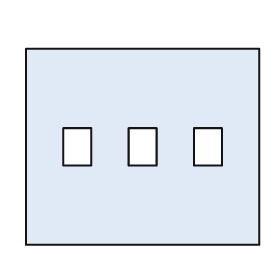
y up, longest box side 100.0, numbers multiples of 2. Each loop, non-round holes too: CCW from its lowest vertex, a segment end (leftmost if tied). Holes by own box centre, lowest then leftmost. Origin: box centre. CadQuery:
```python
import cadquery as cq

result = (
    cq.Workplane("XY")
    .moveTo(-50.0, -42.0)
    .lineTo(50.0, -42.0)
    .lineTo(50.0, 42.0)
    .lineTo(-50.0, 42.0)
    .close()
    .moveTo(-34.0, -8.0)
    .lineTo(-22.0, -8.0)
    .lineTo(-22.0, 8.0)
    .lineTo(-34.0, 8.0)
    .close()
    .moveTo(-6.0, -8.0)
    .lineTo(6.0, -8.0)
    .lineTo(6.0, 8.0)
    .lineTo(-6.0, 8.0)
    .close()
    .moveTo(22.0, -8.0)
    .lineTo(34.0, -8.0)
    .lineTo(34.0, 8.0)
    .lineTo(22.0, 8.0)
    .close()
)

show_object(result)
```